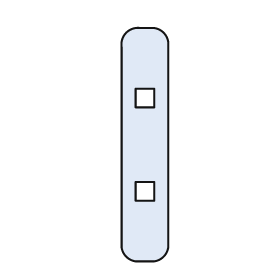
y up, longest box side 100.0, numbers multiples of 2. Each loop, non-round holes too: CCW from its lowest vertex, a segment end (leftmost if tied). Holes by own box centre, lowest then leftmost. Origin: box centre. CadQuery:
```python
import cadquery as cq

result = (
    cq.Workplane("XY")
    .moveTo(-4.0, -50.0)
    .lineTo(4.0, -50.0)
    .threePointArc((8.0, -48.0), (10.0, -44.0))
    .lineTo(10.0, 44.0)
    .threePointArc((8.0, 48.0), (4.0, 50.0))
    .lineTo(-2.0, 50.0)
    .threePointArc((-8.0, 48.0), (-10.0, 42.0))
    .lineTo(-10.0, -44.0)
    .threePointArc((-8.0, -48.0), (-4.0, -50.0))
    .close()
    .moveTo(-4.0, -24.0)
    .lineTo(4.0, -24.0)
    .lineTo(4.0, -16.0)
    .lineTo(-4.0, -16.0)
    .close()
    .moveTo(-4.0, 16.0)
    .lineTo(4.0, 16.0)
    .lineTo(4.0, 24.0)
    .lineTo(-4.0, 24.0)
    .close()
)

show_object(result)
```